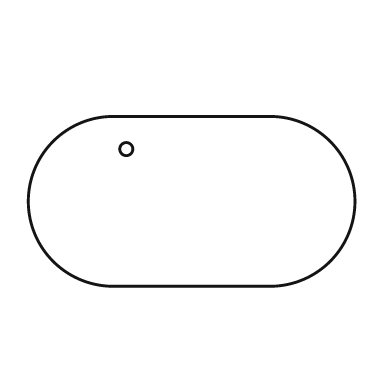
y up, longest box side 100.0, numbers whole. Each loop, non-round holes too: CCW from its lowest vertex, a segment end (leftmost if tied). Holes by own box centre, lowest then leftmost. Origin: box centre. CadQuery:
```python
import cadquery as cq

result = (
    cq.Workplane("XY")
    .moveTo(-24.0, -26.0)
    .lineTo(24.0, -26.0)
    .threePointArc((50.0, 0.0), (24.0, 26.0))
    .lineTo(-24.0, 26.0)
    .threePointArc((-50.0, 0.0), (-24.0, -26.0))
    .close()
    .moveTo(-20.0, 16.0)
    .circle(2.0)
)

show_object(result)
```